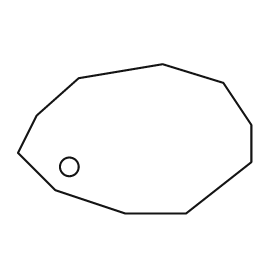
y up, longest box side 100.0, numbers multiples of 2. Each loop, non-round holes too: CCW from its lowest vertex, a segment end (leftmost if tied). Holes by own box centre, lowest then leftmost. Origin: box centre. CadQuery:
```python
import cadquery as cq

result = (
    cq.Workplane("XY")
    .moveTo(-4.0, -32.0)
    .lineTo(22.0, -32.0)
    .lineTo(50.0, -10.0)
    .lineTo(50.0, 6.0)
    .lineTo(38.0, 24.0)
    .lineTo(12.0, 32.0)
    .lineTo(-24.0, 26.0)
    .lineTo(-42.0, 10.0)
    .lineTo(-50.0, -6.0)
    .lineTo(-34.0, -22.0)
    .close()
    .moveTo(-28.0, -12.0)
    .circle(4.0)
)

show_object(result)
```